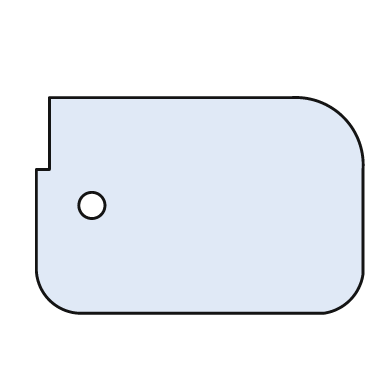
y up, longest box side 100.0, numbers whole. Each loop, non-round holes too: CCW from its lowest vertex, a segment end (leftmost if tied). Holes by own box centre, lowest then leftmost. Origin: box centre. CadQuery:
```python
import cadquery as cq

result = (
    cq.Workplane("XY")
    .moveTo(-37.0, -33.0)
    .lineTo(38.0, -33.0)
    .threePointArc((46.0, -29.0), (50.0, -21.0))
    .lineTo(50.0, 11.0)
    .threePointArc((44.0, 27.0), (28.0, 33.0))
    .lineTo(-46.0, 33.0)
    .lineTo(-46.0, 11.0)
    .lineTo(-50.0, 11.0)
    .lineTo(-50.0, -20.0)
    .threePointArc((-46.0, -29.0), (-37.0, -33.0))
    .close()
    .moveTo(-33.0, 0.0)
    .circle(4.0)
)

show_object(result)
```